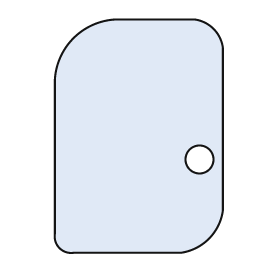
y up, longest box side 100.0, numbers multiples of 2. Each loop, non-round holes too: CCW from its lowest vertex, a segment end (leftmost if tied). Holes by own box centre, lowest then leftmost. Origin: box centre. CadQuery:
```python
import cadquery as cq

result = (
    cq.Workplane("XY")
    .moveTo(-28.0, -50.0)
    .lineTo(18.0, -50.0)
    .threePointArc((30.0, -44.0), (36.0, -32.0))
    .lineTo(36.0, 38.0)
    .threePointArc((32.0, 46.0), (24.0, 50.0))
    .lineTo(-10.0, 50.0)
    .threePointArc((-28.0, 42.0), (-36.0, 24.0))
    .lineTo(-36.0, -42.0)
    .threePointArc((-34.0, -48.0), (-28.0, -50.0))
    .close()
    .moveTo(26.0, -10.0)
    .circle(6.0)
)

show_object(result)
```